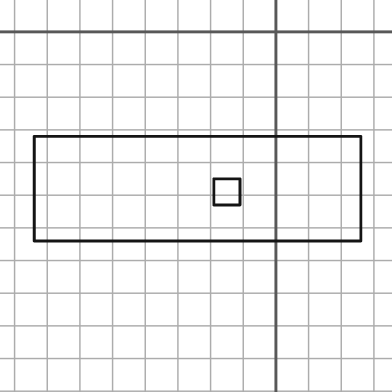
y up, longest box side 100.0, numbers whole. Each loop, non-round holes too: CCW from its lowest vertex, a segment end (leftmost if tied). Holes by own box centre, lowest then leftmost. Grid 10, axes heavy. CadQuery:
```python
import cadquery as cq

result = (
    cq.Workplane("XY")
    .moveTo(-74.0, -64.0)
    .lineTo(26.0, -64.0)
    .lineTo(26.0, -32.0)
    .lineTo(-74.0, -32.0)
    .close()
    .moveTo(-19.0, -53.0)
    .lineTo(-11.0, -53.0)
    .lineTo(-11.0, -45.0)
    .lineTo(-19.0, -45.0)
    .close()
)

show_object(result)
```